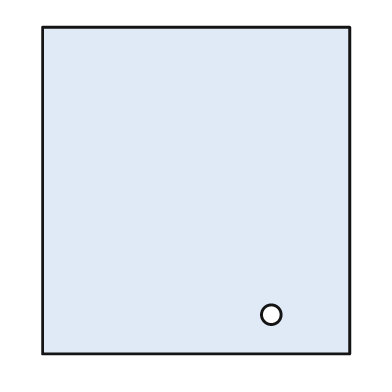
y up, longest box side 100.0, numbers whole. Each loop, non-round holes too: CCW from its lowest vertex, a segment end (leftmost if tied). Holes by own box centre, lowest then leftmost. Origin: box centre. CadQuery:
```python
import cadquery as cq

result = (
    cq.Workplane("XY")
    .moveTo(-47.0, -50.0)
    .lineTo(47.0, -50.0)
    .lineTo(47.0, 50.0)
    .lineTo(-47.0, 50.0)
    .close()
    .moveTo(23.0, -38.0)
    .circle(3.0)
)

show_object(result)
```